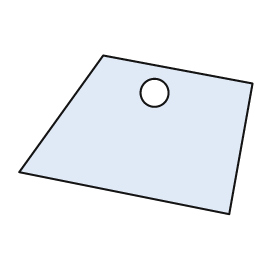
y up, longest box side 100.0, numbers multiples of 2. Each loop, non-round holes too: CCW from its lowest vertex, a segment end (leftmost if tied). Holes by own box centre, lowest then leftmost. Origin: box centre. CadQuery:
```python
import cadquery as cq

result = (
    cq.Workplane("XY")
    .moveTo(40.0, -34.0)
    .lineTo(50.0, 22.0)
    .lineTo(-14.0, 34.0)
    .lineTo(-50.0, -16.0)
    .close()
    .moveTo(8.0, 18.0)
    .circle(6.0)
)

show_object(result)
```